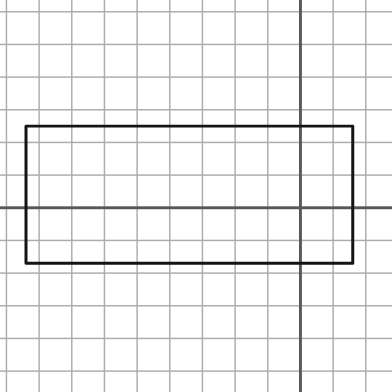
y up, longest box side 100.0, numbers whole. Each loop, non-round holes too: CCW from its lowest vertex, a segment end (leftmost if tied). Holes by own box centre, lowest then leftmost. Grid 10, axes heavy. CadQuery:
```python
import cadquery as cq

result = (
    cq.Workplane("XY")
    .moveTo(-84.0, -17.0)
    .lineTo(16.0, -17.0)
    .lineTo(16.0, 25.0)
    .lineTo(-84.0, 25.0)
    .close()
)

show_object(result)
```